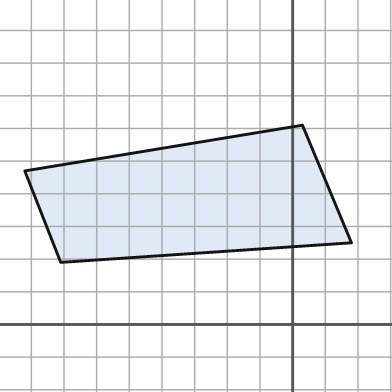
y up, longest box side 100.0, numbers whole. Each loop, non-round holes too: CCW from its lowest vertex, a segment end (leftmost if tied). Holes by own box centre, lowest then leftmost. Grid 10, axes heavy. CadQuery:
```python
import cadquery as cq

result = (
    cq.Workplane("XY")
    .moveTo(-71.0, 19.0)
    .lineTo(18.0, 25.0)
    .lineTo(3.0, 61.0)
    .lineTo(-82.0, 47.0)
    .close()
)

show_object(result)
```